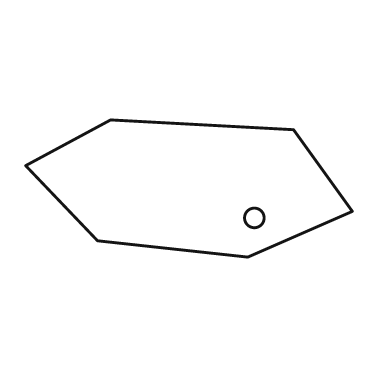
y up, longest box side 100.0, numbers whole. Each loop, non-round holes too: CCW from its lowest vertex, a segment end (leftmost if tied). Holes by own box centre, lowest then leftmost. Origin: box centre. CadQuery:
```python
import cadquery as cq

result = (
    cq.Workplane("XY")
    .moveTo(18.0, -21.0)
    .lineTo(50.0, -7.0)
    .lineTo(32.0, 18.0)
    .lineTo(-24.0, 21.0)
    .lineTo(-50.0, 7.0)
    .lineTo(-28.0, -16.0)
    .close()
    .moveTo(20.0, -9.0)
    .circle(3.0)
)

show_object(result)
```